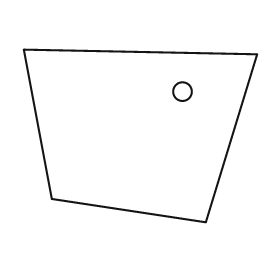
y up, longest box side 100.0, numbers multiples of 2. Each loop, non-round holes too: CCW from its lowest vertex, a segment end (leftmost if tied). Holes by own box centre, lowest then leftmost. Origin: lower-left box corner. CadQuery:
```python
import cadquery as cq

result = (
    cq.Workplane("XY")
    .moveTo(78.0, 0.0)
    .lineTo(100.0, 72.0)
    .lineTo(0.0, 74.0)
    .lineTo(12.0, 10.0)
    .close()
    .moveTo(68.0, 56.0)
    .circle(4.0)
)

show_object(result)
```